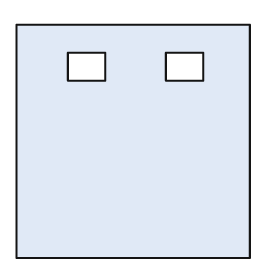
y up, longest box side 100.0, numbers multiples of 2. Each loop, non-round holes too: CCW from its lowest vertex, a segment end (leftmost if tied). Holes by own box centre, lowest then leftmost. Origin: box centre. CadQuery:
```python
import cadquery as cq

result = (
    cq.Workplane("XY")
    .moveTo(-50.0, -50.0)
    .lineTo(50.0, -50.0)
    .lineTo(50.0, 50.0)
    .lineTo(-50.0, 50.0)
    .close()
    .moveTo(-28.0, 26.0)
    .lineTo(-12.0, 26.0)
    .lineTo(-12.0, 38.0)
    .lineTo(-28.0, 38.0)
    .close()
    .moveTo(14.0, 26.0)
    .lineTo(30.0, 26.0)
    .lineTo(30.0, 38.0)
    .lineTo(14.0, 38.0)
    .close()
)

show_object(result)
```